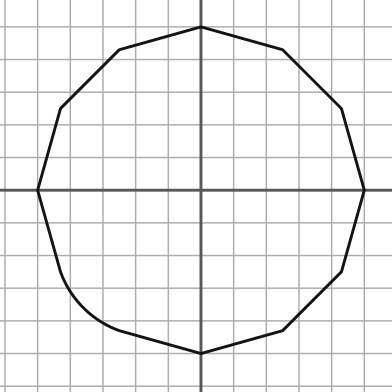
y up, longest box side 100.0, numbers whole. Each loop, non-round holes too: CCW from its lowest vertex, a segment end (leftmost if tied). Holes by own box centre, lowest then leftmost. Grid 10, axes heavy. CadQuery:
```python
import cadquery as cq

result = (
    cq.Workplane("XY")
    .moveTo(0.0, -50.0)
    .lineTo(25.0, -43.0)
    .lineTo(43.0, -25.0)
    .lineTo(50.0, 0.0)
    .lineTo(43.0, 25.0)
    .lineTo(25.0, 43.0)
    .lineTo(0.0, 50.0)
    .lineTo(-25.0, 43.0)
    .lineTo(-43.0, 25.0)
    .lineTo(-50.0, 0.0)
    .lineTo(-43.0, -25.0)
    .threePointArc((-36.0, -36.0), (-25.0, -43.0))
    .close()
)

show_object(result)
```